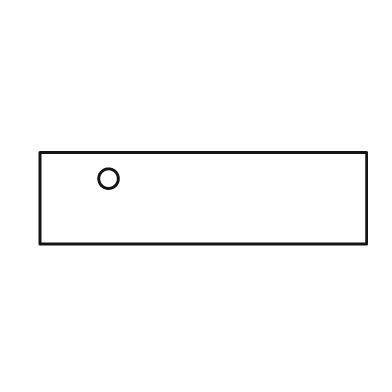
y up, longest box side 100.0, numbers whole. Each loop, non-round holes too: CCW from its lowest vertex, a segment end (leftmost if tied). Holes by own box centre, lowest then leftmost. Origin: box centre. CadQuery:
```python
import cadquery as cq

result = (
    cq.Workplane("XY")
    .moveTo(-50.0, -14.0)
    .lineTo(50.0, -14.0)
    .lineTo(50.0, 14.0)
    .lineTo(-50.0, 14.0)
    .close()
    .moveTo(-29.0, 6.0)
    .circle(3.0)
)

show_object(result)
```